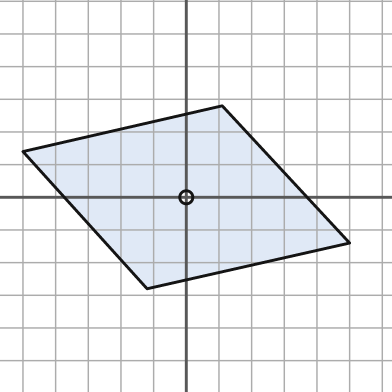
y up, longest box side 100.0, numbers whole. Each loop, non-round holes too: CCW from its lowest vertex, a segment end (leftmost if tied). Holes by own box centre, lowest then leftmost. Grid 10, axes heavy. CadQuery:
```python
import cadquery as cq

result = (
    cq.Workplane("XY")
    .moveTo(-12.0, -28.0)
    .lineTo(50.0, -14.0)
    .lineTo(11.0, 28.0)
    .lineTo(-50.0, 14.0)
    .close()
    .moveTo(0.0, 0.0)
    .circle(2.0)
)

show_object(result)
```